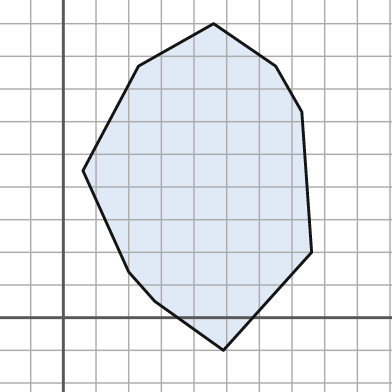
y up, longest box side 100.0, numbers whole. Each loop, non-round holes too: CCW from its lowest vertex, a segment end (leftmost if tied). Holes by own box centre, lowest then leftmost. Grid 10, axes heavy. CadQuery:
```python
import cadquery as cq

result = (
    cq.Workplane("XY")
    .moveTo(49.0, -10.0)
    .lineTo(76.0, 20.0)
    .lineTo(73.0, 63.0)
    .lineTo(65.0, 77.0)
    .lineTo(46.0, 90.0)
    .lineTo(23.0, 77.0)
    .lineTo(6.0, 45.0)
    .lineTo(20.0, 14.0)
    .lineTo(28.0, 5.0)
    .close()
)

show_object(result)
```